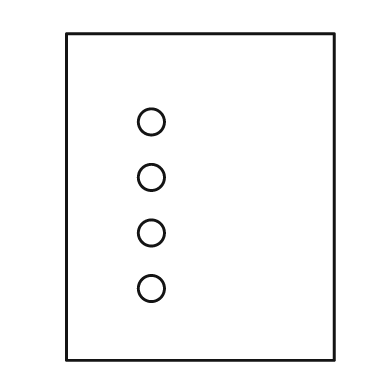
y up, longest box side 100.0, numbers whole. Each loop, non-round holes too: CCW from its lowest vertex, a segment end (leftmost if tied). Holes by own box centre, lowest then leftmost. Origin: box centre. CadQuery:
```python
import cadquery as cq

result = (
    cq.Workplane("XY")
    .moveTo(-41.0, -50.0)
    .lineTo(41.0, -50.0)
    .lineTo(41.0, 50.0)
    .lineTo(-41.0, 50.0)
    .close()
    .moveTo(-15.0, -28.0)
    .circle(4.0)
    .moveTo(-15.0, -11.0)
    .circle(4.0)
    .moveTo(-15.0, 6.0)
    .circle(4.0)
    .moveTo(-15.0, 23.0)
    .circle(4.0)
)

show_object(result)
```